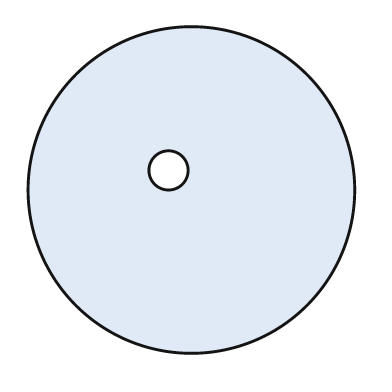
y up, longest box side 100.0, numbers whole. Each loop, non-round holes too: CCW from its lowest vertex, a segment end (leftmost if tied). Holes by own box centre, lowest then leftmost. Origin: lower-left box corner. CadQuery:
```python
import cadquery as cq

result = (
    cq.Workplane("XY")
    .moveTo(50.0, 50.0)
    .circle(50.0)
    .moveTo(43.0, 56.0)
    .circle(6.0)
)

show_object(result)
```